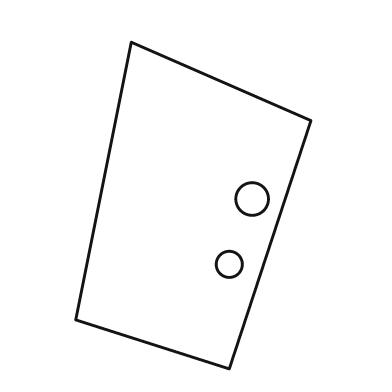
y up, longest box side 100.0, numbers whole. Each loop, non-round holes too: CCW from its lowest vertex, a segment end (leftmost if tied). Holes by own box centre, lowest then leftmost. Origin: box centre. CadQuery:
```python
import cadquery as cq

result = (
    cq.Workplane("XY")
    .moveTo(11.0, -50.0)
    .lineTo(36.0, 26.0)
    .lineTo(-19.0, 50.0)
    .lineTo(-36.0, -35.0)
    .close()
    .moveTo(11.0, -18.0)
    .circle(4.0)
    .moveTo(18.0, 2.0)
    .circle(5.0)
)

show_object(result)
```